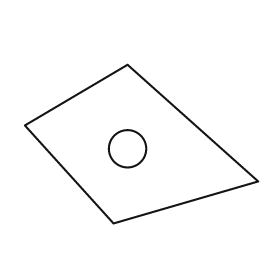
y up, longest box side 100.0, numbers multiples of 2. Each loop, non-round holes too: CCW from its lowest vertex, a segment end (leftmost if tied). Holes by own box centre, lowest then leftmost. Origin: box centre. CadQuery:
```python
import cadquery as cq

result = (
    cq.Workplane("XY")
    .moveTo(-12.0, -34.0)
    .lineTo(50.0, -16.0)
    .lineTo(-6.0, 34.0)
    .lineTo(-50.0, 8.0)
    .close()
    .moveTo(-6.0, -2.0)
    .circle(8.0)
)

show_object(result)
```